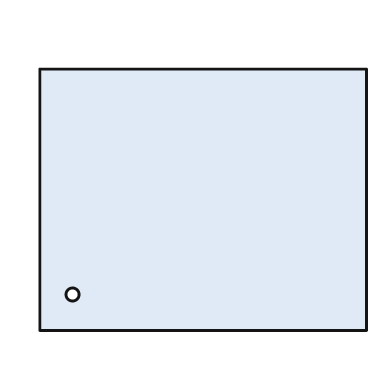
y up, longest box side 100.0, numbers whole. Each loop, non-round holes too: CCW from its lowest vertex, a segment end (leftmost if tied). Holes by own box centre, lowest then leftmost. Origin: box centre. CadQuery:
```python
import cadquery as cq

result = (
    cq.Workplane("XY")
    .moveTo(-50.0, -40.0)
    .lineTo(50.0, -40.0)
    .lineTo(50.0, 40.0)
    .lineTo(-50.0, 40.0)
    .close()
    .moveTo(-40.0, -29.0)
    .circle(2.0)
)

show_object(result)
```